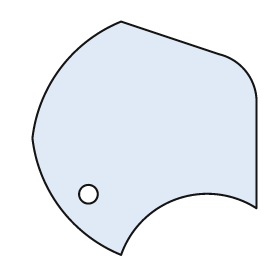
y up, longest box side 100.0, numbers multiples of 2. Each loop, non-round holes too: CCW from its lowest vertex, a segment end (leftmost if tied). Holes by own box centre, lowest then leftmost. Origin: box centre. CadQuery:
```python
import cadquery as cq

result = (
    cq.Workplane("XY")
    .moveTo(-10.0, -50.0)
    .threePointArc((14.0, -26.0), (48.0, -30.0))
    .lineTo(48.0, 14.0)
    .threePointArc((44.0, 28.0), (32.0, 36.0))
    .lineTo(-10.0, 50.0)
    .threePointArc((-36.0, 30.0), (-48.0, 0.0))
    .threePointArc((-36.0, -30.0), (-10.0, -50.0))
    .close()
    .moveTo(-24.0, -24.0)
    .circle(4.0)
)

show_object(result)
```